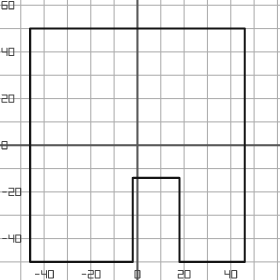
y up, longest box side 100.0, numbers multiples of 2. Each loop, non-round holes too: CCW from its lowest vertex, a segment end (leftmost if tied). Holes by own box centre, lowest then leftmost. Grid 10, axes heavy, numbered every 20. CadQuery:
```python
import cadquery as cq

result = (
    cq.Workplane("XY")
    .moveTo(-46.0, -50.0)
    .lineTo(-2.0, -50.0)
    .lineTo(-2.0, -14.0)
    .lineTo(18.0, -14.0)
    .lineTo(18.0, -50.0)
    .lineTo(46.0, -50.0)
    .lineTo(46.0, 50.0)
    .lineTo(-46.0, 50.0)
    .close()
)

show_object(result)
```